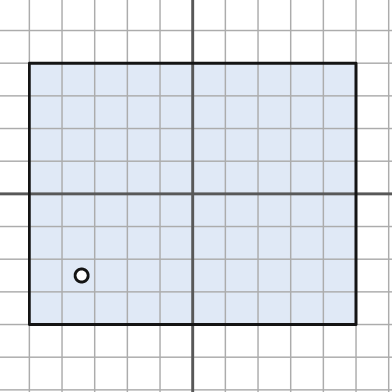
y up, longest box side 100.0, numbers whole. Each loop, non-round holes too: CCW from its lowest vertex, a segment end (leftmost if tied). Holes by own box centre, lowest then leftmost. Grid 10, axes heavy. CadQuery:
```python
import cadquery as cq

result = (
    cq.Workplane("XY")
    .moveTo(-50.0, -40.0)
    .lineTo(50.0, -40.0)
    .lineTo(50.0, 40.0)
    .lineTo(-50.0, 40.0)
    .close()
    .moveTo(-34.0, -25.0)
    .circle(2.0)
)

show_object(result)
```